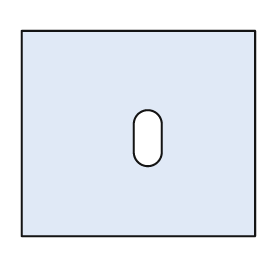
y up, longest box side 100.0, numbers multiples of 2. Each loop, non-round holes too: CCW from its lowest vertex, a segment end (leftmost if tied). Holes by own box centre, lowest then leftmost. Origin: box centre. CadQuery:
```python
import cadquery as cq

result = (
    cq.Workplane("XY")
    .moveTo(-50.0, -44.0)
    .lineTo(50.0, -44.0)
    .lineTo(50.0, 44.0)
    .lineTo(-50.0, 44.0)
    .close()
    .moveTo(-2.0, -8.0)
    .threePointArc((4.0, -14.0), (10.0, -8.0))
    .lineTo(10.0, 4.0)
    .threePointArc((4.0, 10.0), (-2.0, 4.0))
    .close()
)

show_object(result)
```